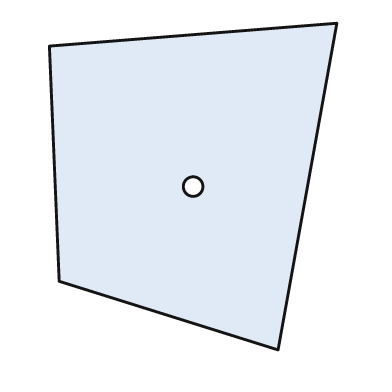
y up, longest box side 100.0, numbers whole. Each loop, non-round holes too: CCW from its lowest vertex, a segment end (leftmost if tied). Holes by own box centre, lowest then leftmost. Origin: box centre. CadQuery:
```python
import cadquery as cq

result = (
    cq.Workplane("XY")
    .moveTo(26.0, -50.0)
    .lineTo(44.0, 50.0)
    .lineTo(-44.0, 43.0)
    .lineTo(-41.0, -29.0)
    .close()
    .moveTo(0.0, 0.0)
    .circle(3.0)
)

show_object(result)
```